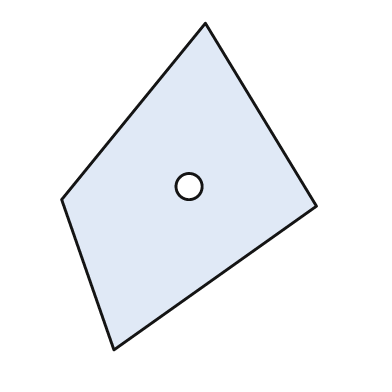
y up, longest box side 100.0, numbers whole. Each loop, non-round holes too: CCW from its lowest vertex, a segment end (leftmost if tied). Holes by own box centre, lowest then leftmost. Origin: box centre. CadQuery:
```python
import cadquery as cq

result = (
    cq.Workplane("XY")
    .moveTo(-23.0, -50.0)
    .lineTo(39.0, -6.0)
    .lineTo(5.0, 50.0)
    .lineTo(-39.0, -4.0)
    .close()
    .moveTo(0.0, 0.0)
    .circle(4.0)
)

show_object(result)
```